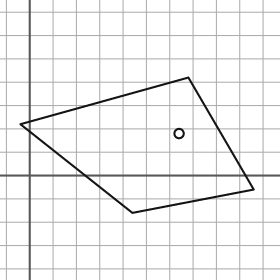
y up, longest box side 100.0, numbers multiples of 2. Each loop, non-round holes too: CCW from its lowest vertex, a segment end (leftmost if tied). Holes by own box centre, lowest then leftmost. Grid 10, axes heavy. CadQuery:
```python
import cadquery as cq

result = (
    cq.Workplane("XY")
    .moveTo(44.0, -16.0)
    .lineTo(96.0, -6.0)
    .lineTo(68.0, 42.0)
    .lineTo(-4.0, 22.0)
    .close()
    .moveTo(64.0, 18.0)
    .circle(2.0)
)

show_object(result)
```